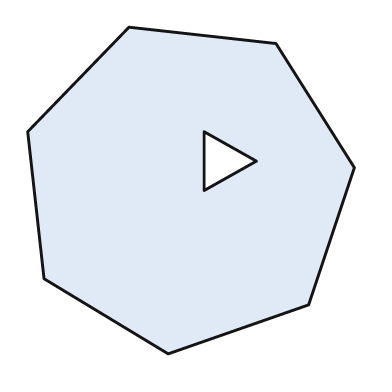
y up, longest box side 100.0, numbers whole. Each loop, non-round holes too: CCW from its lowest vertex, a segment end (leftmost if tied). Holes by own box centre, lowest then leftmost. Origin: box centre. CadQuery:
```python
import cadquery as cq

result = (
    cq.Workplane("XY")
    .moveTo(-7.0, -50.0)
    .lineTo(36.0, -35.0)
    .lineTo(50.0, 7.0)
    .lineTo(26.0, 45.0)
    .lineTo(-19.0, 50.0)
    .lineTo(-50.0, 18.0)
    .lineTo(-45.0, -27.0)
    .close()
    .moveTo(4.0, 0.0)
    .lineTo(20.0, 9.0)
    .lineTo(4.0, 18.0)
    .close()
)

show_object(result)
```